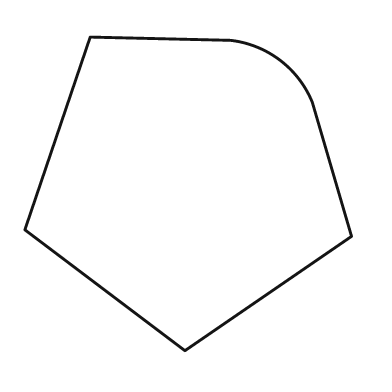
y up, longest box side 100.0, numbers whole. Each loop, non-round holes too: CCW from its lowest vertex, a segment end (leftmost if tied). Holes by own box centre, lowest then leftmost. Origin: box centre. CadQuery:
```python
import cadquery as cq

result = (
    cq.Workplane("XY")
    .moveTo(-1.0, -48.0)
    .lineTo(50.0, -13.0)
    .lineTo(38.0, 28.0)
    .threePointArc((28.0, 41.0), (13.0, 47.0))
    .lineTo(-30.0, 48.0)
    .lineTo(-50.0, -11.0)
    .close()
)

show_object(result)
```